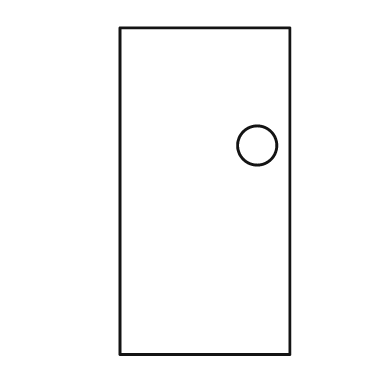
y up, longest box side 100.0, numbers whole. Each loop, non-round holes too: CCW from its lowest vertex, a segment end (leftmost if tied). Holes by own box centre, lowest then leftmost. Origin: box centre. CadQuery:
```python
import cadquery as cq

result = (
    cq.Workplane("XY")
    .moveTo(-26.0, -50.0)
    .lineTo(26.0, -50.0)
    .lineTo(26.0, 50.0)
    .lineTo(-26.0, 50.0)
    .close()
    .moveTo(16.0, 14.0)
    .circle(6.0)
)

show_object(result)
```